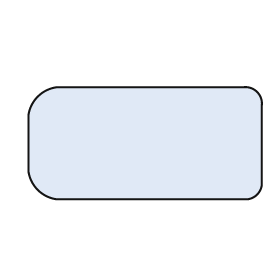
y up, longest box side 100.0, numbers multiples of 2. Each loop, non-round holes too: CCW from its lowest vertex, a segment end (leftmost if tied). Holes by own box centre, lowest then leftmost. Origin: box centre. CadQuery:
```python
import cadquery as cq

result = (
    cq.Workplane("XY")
    .moveTo(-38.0, -24.0)
    .lineTo(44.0, -24.0)
    .threePointArc((48.0, -22.0), (50.0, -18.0))
    .lineTo(50.0, 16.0)
    .threePointArc((48.0, 22.0), (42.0, 24.0))
    .lineTo(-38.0, 24.0)
    .threePointArc((-46.0, 20.0), (-50.0, 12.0))
    .lineTo(-50.0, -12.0)
    .threePointArc((-46.0, -20.0), (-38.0, -24.0))
    .close()
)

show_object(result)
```